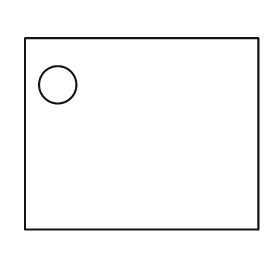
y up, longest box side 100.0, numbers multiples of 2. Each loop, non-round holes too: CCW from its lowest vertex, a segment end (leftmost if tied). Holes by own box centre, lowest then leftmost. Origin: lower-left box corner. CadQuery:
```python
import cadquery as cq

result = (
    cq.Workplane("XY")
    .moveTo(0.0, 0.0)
    .lineTo(100.0, 0.0)
    .lineTo(100.0, 82.0)
    .lineTo(0.0, 82.0)
    .close()
    .moveTo(14.0, 62.0)
    .circle(8.0)
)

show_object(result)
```